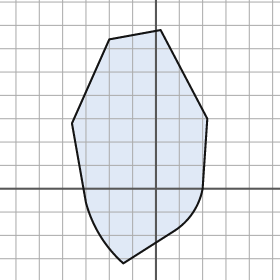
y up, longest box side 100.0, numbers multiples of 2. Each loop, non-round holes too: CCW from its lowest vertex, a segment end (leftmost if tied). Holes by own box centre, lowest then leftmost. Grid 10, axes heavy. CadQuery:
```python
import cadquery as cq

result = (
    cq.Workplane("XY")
    .moveTo(-14.0, -32.0)
    .lineTo(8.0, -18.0)
    .threePointArc((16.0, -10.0), (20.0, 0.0))
    .lineTo(22.0, 30.0)
    .lineTo(2.0, 68.0)
    .lineTo(-20.0, 64.0)
    .lineTo(-36.0, 28.0)
    .lineTo(-30.0, -6.0)
    .threePointArc((-24.0, -20.0), (-14.0, -32.0))
    .close()
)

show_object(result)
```